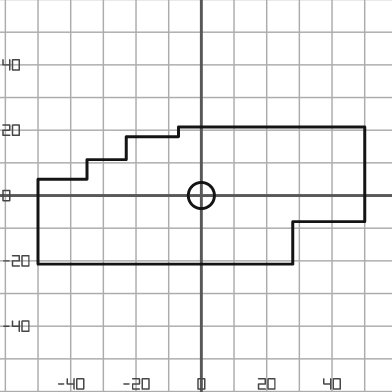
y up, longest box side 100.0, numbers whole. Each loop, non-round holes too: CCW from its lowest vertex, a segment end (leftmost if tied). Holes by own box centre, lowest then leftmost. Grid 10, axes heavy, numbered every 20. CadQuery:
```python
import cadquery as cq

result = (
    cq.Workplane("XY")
    .moveTo(-50.0, -21.0)
    .lineTo(28.0, -21.0)
    .lineTo(28.0, -8.0)
    .lineTo(50.0, -8.0)
    .lineTo(50.0, 21.0)
    .lineTo(-7.0, 21.0)
    .lineTo(-7.0, 18.0)
    .lineTo(-23.0, 18.0)
    .lineTo(-23.0, 11.0)
    .lineTo(-35.0, 11.0)
    .lineTo(-35.0, 5.0)
    .lineTo(-50.0, 5.0)
    .close()
    .moveTo(0.0, 0.0)
    .circle(4.0)
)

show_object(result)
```